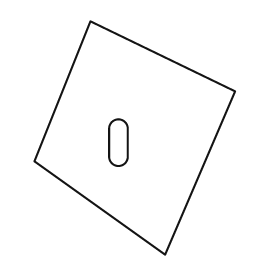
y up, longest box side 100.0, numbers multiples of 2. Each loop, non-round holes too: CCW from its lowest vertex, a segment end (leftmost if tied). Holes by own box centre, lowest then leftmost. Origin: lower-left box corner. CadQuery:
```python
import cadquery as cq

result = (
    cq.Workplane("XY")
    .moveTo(56.0, 0.0)
    .lineTo(86.0, 70.0)
    .lineTo(24.0, 100.0)
    .lineTo(0.0, 40.0)
    .close()
    .moveTo(32.0, 42.0)
    .threePointArc((36.0, 38.0), (40.0, 42.0))
    .lineTo(40.0, 54.0)
    .threePointArc((36.0, 58.0), (32.0, 54.0))
    .close()
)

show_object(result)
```